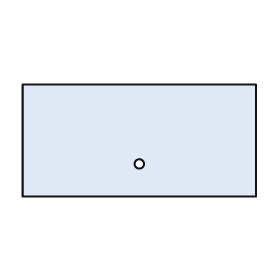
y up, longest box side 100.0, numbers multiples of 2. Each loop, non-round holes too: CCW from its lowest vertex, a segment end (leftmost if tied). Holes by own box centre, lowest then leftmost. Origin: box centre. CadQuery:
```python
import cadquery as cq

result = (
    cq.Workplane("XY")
    .moveTo(-50.0, -24.0)
    .lineTo(50.0, -24.0)
    .lineTo(50.0, 24.0)
    .lineTo(-50.0, 24.0)
    .close()
    .moveTo(0.0, -10.0)
    .circle(2.0)
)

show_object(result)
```